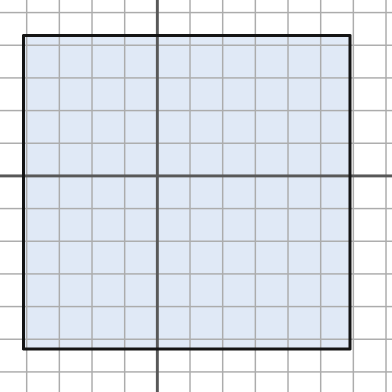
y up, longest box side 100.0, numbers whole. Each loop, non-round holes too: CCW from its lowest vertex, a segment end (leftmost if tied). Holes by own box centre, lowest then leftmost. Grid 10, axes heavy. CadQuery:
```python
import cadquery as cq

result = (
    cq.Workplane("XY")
    .moveTo(-41.0, -53.0)
    .lineTo(59.0, -53.0)
    .lineTo(59.0, 43.0)
    .lineTo(-41.0, 43.0)
    .close()
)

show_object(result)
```